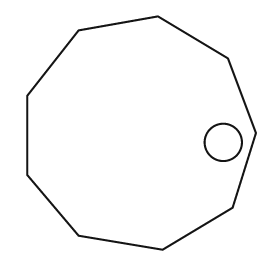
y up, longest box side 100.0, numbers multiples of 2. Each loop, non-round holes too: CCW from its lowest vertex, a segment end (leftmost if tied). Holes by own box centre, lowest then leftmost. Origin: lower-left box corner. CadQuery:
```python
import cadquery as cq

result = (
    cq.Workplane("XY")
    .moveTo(58.0, 0.0)
    .lineTo(88.0, 18.0)
    .lineTo(98.0, 50.0)
    .lineTo(86.0, 82.0)
    .lineTo(56.0, 100.0)
    .lineTo(22.0, 94.0)
    .lineTo(0.0, 66.0)
    .lineTo(0.0, 32.0)
    .lineTo(22.0, 6.0)
    .close()
    .moveTo(84.0, 46.0)
    .circle(8.0)
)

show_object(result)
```